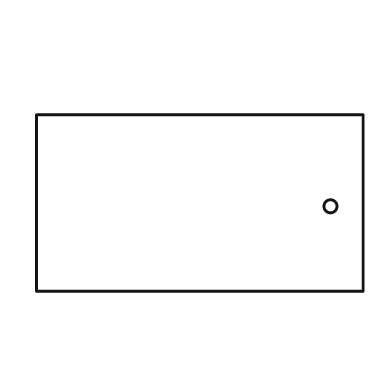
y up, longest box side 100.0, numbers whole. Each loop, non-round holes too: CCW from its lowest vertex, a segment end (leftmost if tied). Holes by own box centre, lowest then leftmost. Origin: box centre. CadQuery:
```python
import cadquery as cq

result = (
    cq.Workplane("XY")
    .moveTo(-50.0, -27.0)
    .lineTo(50.0, -27.0)
    .lineTo(50.0, 27.0)
    .lineTo(-50.0, 27.0)
    .close()
    .moveTo(40.0, -1.0)
    .circle(2.0)
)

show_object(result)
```